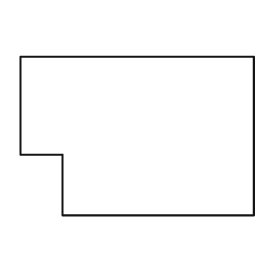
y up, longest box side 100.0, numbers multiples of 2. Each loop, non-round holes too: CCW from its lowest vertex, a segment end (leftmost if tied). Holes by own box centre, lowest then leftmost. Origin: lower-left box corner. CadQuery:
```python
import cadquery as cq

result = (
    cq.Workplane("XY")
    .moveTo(18.0, 0.0)
    .lineTo(100.0, 0.0)
    .lineTo(100.0, 68.0)
    .lineTo(0.0, 68.0)
    .lineTo(0.0, 26.0)
    .lineTo(18.0, 26.0)
    .close()
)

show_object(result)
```